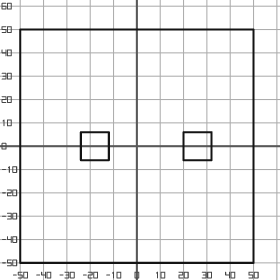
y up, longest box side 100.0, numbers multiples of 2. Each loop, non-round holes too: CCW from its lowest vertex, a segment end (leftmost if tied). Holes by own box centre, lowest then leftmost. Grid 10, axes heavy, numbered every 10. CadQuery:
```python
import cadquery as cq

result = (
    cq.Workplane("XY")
    .moveTo(-50.0, -50.0)
    .lineTo(50.0, -50.0)
    .lineTo(50.0, 50.0)
    .lineTo(-50.0, 50.0)
    .close()
    .moveTo(-24.0, -6.0)
    .lineTo(-12.0, -6.0)
    .lineTo(-12.0, 6.0)
    .lineTo(-24.0, 6.0)
    .close()
    .moveTo(20.0, -6.0)
    .lineTo(32.0, -6.0)
    .lineTo(32.0, 6.0)
    .lineTo(20.0, 6.0)
    .close()
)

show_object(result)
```